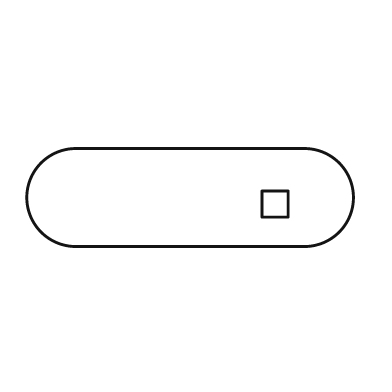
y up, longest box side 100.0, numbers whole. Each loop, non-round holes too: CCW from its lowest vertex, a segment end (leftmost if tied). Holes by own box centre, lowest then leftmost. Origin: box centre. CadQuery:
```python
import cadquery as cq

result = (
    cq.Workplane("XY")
    .moveTo(-35.0, -15.0)
    .lineTo(35.0, -15.0)
    .threePointArc((50.0, 0.0), (35.0, 15.0))
    .lineTo(-35.0, 15.0)
    .threePointArc((-50.0, 0.0), (-35.0, -15.0))
    .close()
    .moveTo(22.0, -6.0)
    .lineTo(30.0, -6.0)
    .lineTo(30.0, 2.0)
    .lineTo(22.0, 2.0)
    .close()
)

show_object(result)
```